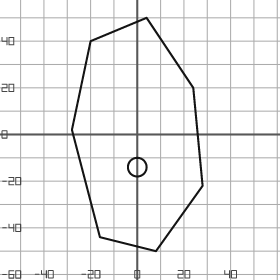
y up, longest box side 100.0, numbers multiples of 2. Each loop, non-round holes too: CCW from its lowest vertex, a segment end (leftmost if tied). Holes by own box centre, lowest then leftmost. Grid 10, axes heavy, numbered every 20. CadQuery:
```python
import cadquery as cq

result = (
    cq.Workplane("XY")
    .moveTo(8.0, -50.0)
    .lineTo(28.0, -22.0)
    .lineTo(24.0, 20.0)
    .lineTo(4.0, 50.0)
    .lineTo(-20.0, 40.0)
    .lineTo(-28.0, 2.0)
    .lineTo(-16.0, -44.0)
    .close()
    .moveTo(0.0, -14.0)
    .circle(4.0)
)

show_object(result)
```